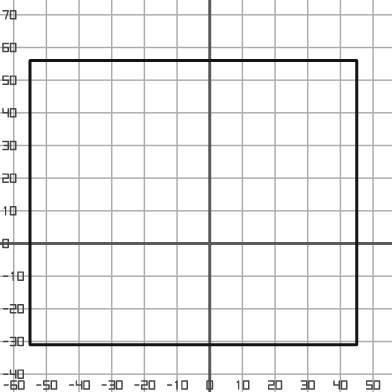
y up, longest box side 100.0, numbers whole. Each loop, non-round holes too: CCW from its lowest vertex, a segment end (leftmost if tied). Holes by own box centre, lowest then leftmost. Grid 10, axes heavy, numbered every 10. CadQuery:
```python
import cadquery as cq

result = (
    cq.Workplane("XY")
    .moveTo(-55.0, -31.0)
    .lineTo(45.0, -31.0)
    .lineTo(45.0, 56.0)
    .lineTo(-55.0, 56.0)
    .close()
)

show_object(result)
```